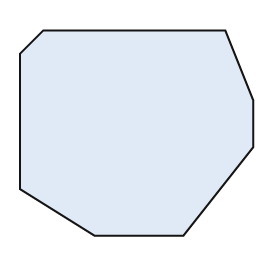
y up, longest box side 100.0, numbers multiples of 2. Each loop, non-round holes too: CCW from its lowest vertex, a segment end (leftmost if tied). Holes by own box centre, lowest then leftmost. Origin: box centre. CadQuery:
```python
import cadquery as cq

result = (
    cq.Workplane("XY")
    .moveTo(-18.0, -44.0)
    .lineTo(20.0, -44.0)
    .lineTo(50.0, -6.0)
    .lineTo(50.0, 14.0)
    .lineTo(38.0, 44.0)
    .lineTo(-40.0, 44.0)
    .lineTo(-50.0, 34.0)
    .lineTo(-50.0, -24.0)
    .close()
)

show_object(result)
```